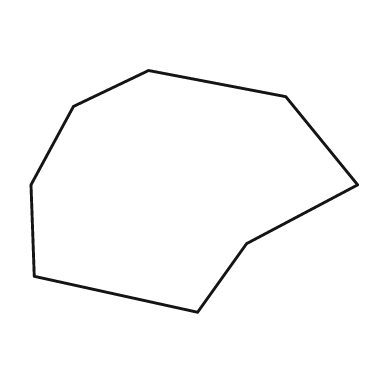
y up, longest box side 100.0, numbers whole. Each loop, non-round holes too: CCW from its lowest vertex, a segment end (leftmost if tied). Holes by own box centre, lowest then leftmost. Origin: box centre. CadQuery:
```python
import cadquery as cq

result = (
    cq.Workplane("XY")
    .moveTo(1.0, -37.0)
    .lineTo(16.0, -16.0)
    .lineTo(50.0, 2.0)
    .lineTo(28.0, 29.0)
    .lineTo(-14.0, 37.0)
    .lineTo(-37.0, 26.0)
    .lineTo(-50.0, 2.0)
    .lineTo(-49.0, -26.0)
    .close()
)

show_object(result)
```